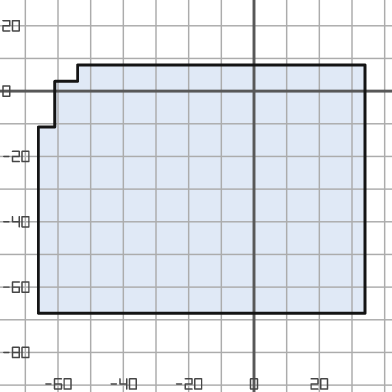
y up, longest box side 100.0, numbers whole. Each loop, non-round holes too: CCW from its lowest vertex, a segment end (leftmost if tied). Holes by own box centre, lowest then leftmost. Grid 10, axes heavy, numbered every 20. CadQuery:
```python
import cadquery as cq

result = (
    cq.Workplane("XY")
    .moveTo(-66.0, -68.0)
    .lineTo(34.0, -68.0)
    .lineTo(34.0, 8.0)
    .lineTo(-54.0, 8.0)
    .lineTo(-54.0, 3.0)
    .lineTo(-61.0, 3.0)
    .lineTo(-61.0, -11.0)
    .lineTo(-66.0, -11.0)
    .close()
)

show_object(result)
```